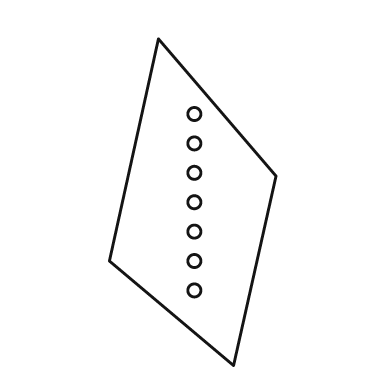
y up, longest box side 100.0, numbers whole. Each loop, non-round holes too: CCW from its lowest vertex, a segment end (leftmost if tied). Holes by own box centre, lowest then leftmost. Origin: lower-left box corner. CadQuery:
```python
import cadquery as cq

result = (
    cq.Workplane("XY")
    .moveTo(38.0, 0.0)
    .lineTo(51.0, 58.0)
    .lineTo(15.0, 100.0)
    .lineTo(0.0, 32.0)
    .close()
    .moveTo(26.0, 23.0)
    .circle(2.0)
    .moveTo(26.0, 32.0)
    .circle(2.0)
    .moveTo(26.0, 41.0)
    .circle(2.0)
    .moveTo(26.0, 50.0)
    .circle(2.0)
    .moveTo(26.0, 59.0)
    .circle(2.0)
    .moveTo(26.0, 68.0)
    .circle(2.0)
    .moveTo(26.0, 77.0)
    .circle(2.0)
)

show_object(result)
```